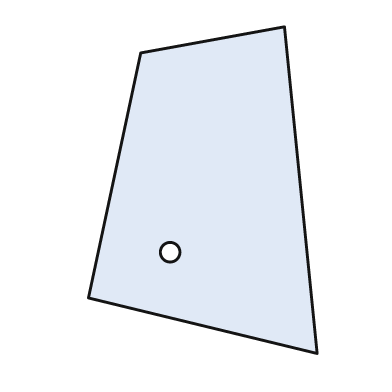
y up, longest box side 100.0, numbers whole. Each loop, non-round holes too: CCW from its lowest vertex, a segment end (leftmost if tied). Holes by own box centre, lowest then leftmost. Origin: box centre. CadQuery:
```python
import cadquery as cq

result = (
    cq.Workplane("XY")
    .moveTo(35.0, -50.0)
    .lineTo(25.0, 50.0)
    .lineTo(-19.0, 42.0)
    .lineTo(-35.0, -33.0)
    .close()
    .moveTo(-10.0, -19.0)
    .circle(3.0)
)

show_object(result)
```